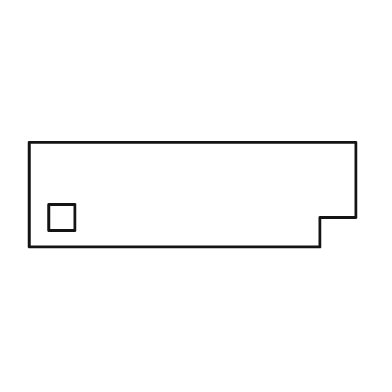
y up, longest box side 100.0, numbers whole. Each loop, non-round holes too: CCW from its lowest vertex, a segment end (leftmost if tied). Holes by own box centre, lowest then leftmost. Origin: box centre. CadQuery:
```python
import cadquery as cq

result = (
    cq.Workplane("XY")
    .moveTo(-50.0, -16.0)
    .lineTo(39.0, -16.0)
    .lineTo(39.0, -7.0)
    .lineTo(50.0, -7.0)
    .lineTo(50.0, 16.0)
    .lineTo(-50.0, 16.0)
    .close()
    .moveTo(-44.0, -11.0)
    .lineTo(-36.0, -11.0)
    .lineTo(-36.0, -3.0)
    .lineTo(-44.0, -3.0)
    .close()
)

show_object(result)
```